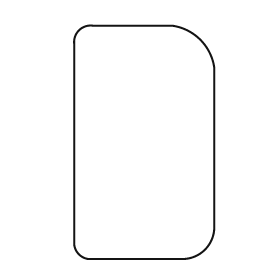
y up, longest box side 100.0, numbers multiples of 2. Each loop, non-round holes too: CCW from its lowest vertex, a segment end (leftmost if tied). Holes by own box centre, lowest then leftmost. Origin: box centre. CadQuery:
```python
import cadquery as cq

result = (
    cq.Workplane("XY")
    .moveTo(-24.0, -50.0)
    .lineTo(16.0, -50.0)
    .threePointArc((26.0, -46.0), (30.0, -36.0))
    .lineTo(30.0, 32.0)
    .threePointArc((24.0, 44.0), (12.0, 50.0))
    .lineTo(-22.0, 50.0)
    .threePointArc((-28.0, 48.0), (-30.0, 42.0))
    .lineTo(-30.0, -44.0)
    .threePointArc((-28.0, -48.0), (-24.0, -50.0))
    .close()
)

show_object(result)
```